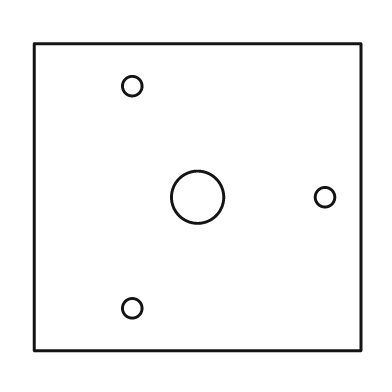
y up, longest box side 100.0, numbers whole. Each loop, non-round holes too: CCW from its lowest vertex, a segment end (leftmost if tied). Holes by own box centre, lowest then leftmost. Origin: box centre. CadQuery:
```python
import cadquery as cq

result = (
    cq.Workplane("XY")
    .moveTo(-50.0, -47.0)
    .lineTo(50.0, -47.0)
    .lineTo(50.0, 47.0)
    .lineTo(-50.0, 47.0)
    .close()
    .moveTo(-20.0, -34.0)
    .circle(3.0)
    .moveTo(0.0, 0.0)
    .circle(8.0)
    .moveTo(39.0, 0.0)
    .circle(3.0)
    .moveTo(-20.0, 34.0)
    .circle(3.0)
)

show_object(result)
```